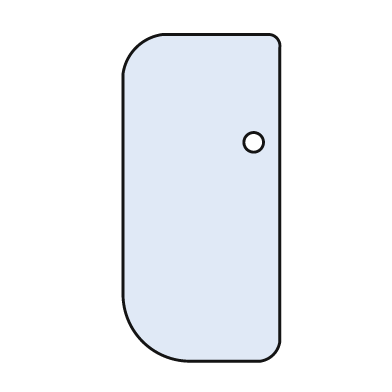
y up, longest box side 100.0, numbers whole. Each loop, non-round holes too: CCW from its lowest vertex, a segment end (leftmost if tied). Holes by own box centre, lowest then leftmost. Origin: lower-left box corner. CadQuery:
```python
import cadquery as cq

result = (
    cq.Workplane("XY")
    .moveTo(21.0, 0.0)
    .lineTo(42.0, 0.0)
    .threePointArc((46.0, 2.0), (48.0, 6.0))
    .lineTo(48.0, 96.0)
    .threePointArc((47.0, 99.0), (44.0, 100.0))
    .lineTo(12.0, 100.0)
    .threePointArc((4.0, 96.0), (0.0, 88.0))
    .lineTo(0.0, 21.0)
    .threePointArc((6.0, 6.0), (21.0, 0.0))
    .close()
    .moveTo(40.0, 67.0)
    .circle(3.0)
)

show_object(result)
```